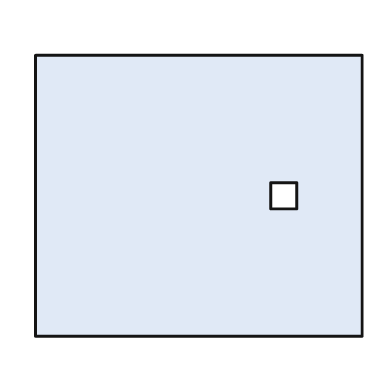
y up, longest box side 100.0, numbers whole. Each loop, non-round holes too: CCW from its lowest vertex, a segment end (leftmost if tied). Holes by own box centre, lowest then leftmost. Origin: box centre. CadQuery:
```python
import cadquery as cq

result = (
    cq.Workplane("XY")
    .moveTo(-50.0, -43.0)
    .lineTo(50.0, -43.0)
    .lineTo(50.0, 43.0)
    .lineTo(-50.0, 43.0)
    .close()
    .moveTo(22.0, -4.0)
    .lineTo(30.0, -4.0)
    .lineTo(30.0, 4.0)
    .lineTo(22.0, 4.0)
    .close()
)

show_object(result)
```